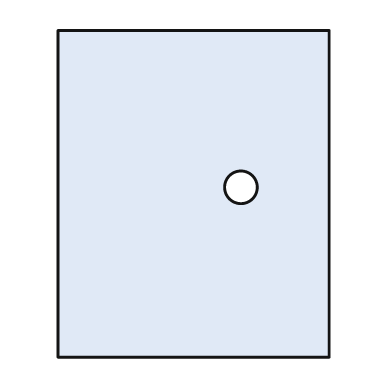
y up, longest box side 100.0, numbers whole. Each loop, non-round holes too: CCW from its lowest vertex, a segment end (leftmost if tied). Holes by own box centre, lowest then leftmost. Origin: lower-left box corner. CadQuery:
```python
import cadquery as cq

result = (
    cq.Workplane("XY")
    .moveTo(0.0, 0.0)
    .lineTo(83.0, 0.0)
    .lineTo(83.0, 100.0)
    .lineTo(0.0, 100.0)
    .close()
    .moveTo(56.0, 52.0)
    .circle(5.0)
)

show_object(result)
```